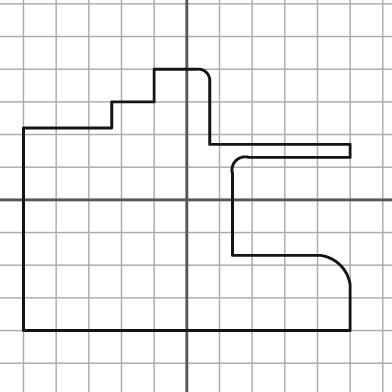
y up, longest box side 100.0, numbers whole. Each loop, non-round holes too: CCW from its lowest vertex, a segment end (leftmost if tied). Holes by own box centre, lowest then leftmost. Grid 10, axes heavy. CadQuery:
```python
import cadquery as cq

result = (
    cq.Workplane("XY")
    .moveTo(-50.0, -40.0)
    .lineTo(50.0, -40.0)
    .lineTo(50.0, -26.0)
    .threePointArc((47.0, -20.0), (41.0, -17.0))
    .lineTo(14.0, -17.0)
    .lineTo(14.0, 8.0)
    .threePointArc((15.0, 12.0), (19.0, 13.0))
    .lineTo(50.0, 13.0)
    .lineTo(50.0, 17.0)
    .lineTo(7.0, 17.0)
    .lineTo(7.0, 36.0)
    .threePointArc((6.0, 39.0), (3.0, 40.0))
    .lineTo(-10.0, 40.0)
    .lineTo(-10.0, 30.0)
    .lineTo(-23.0, 30.0)
    .lineTo(-23.0, 22.0)
    .lineTo(-50.0, 22.0)
    .close()
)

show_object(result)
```